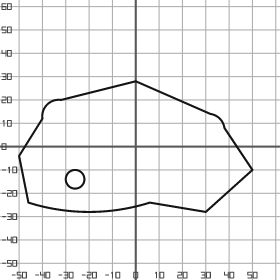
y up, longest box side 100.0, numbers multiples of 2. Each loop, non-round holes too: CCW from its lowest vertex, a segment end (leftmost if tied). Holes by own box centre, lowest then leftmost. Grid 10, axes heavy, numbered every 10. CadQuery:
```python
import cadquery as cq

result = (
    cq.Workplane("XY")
    .moveTo(30.0, -28.0)
    .lineTo(50.0, -10.0)
    .lineTo(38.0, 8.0)
    .threePointArc((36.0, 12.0), (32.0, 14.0))
    .lineTo(0.0, 28.0)
    .lineTo(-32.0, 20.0)
    .threePointArc((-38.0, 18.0), (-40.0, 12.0))
    .lineTo(-50.0, -4.0)
    .lineTo(-46.0, -24.0)
    .threePointArc((-20.0, -28.0), (6.0, -24.0))
    .close()
    .moveTo(-26.0, -14.0)
    .circle(4.0)
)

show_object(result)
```